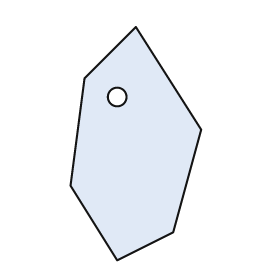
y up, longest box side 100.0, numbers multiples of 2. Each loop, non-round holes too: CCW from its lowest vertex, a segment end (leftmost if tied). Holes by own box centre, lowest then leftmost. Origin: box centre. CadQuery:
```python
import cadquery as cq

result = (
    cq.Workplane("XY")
    .moveTo(-8.0, -50.0)
    .lineTo(16.0, -38.0)
    .lineTo(28.0, 6.0)
    .lineTo(0.0, 50.0)
    .lineTo(-22.0, 28.0)
    .lineTo(-28.0, -18.0)
    .close()
    .moveTo(-8.0, 20.0)
    .circle(4.0)
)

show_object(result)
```